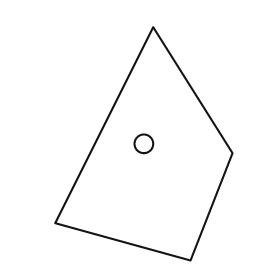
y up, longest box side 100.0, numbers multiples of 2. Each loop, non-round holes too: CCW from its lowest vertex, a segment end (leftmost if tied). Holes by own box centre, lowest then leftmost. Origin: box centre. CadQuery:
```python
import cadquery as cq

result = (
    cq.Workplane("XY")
    .moveTo(20.0, -50.0)
    .lineTo(38.0, -4.0)
    .lineTo(4.0, 50.0)
    .lineTo(-38.0, -34.0)
    .close()
    .moveTo(0.0, 0.0)
    .circle(4.0)
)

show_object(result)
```